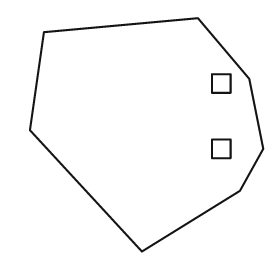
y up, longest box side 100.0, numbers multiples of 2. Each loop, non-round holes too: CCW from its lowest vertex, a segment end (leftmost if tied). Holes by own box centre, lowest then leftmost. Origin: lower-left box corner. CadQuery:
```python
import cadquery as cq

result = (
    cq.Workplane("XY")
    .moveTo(48.0, 0.0)
    .lineTo(90.0, 26.0)
    .lineTo(100.0, 44.0)
    .lineTo(94.0, 74.0)
    .lineTo(72.0, 100.0)
    .lineTo(6.0, 94.0)
    .lineTo(0.0, 52.0)
    .close()
    .moveTo(78.0, 40.0)
    .lineTo(86.0, 40.0)
    .lineTo(86.0, 48.0)
    .lineTo(78.0, 48.0)
    .close()
    .moveTo(78.0, 68.0)
    .lineTo(86.0, 68.0)
    .lineTo(86.0, 76.0)
    .lineTo(78.0, 76.0)
    .close()
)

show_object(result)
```